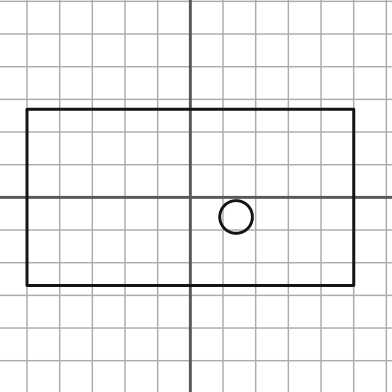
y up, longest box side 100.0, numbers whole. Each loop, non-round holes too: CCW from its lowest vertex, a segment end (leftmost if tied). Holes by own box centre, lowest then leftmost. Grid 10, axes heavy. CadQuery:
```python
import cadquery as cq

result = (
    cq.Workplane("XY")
    .moveTo(-50.0, -27.0)
    .lineTo(50.0, -27.0)
    .lineTo(50.0, 27.0)
    .lineTo(-50.0, 27.0)
    .close()
    .moveTo(14.0, -6.0)
    .circle(5.0)
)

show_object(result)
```